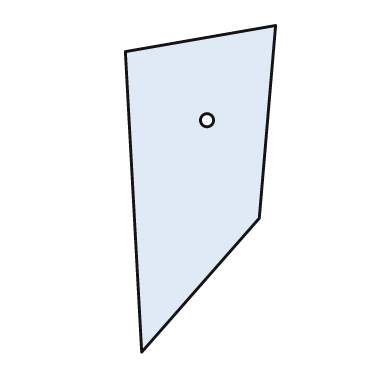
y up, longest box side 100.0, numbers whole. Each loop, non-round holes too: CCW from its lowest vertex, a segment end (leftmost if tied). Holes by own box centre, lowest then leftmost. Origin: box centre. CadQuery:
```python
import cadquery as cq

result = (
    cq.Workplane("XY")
    .moveTo(-18.0, -50.0)
    .lineTo(18.0, -9.0)
    .lineTo(23.0, 50.0)
    .lineTo(-23.0, 42.0)
    .close()
    .moveTo(2.0, 21.0)
    .circle(2.0)
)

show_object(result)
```